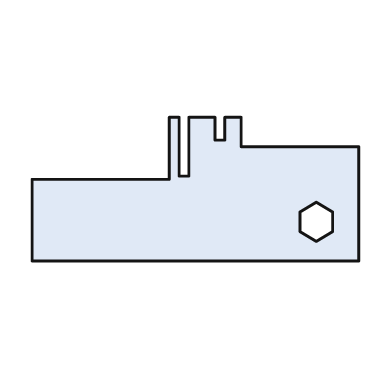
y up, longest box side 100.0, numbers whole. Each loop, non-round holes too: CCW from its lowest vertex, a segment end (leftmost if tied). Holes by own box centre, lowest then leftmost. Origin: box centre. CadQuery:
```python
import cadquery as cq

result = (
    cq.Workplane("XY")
    .moveTo(-50.0, -22.0)
    .lineTo(50.0, -22.0)
    .lineTo(50.0, 13.0)
    .lineTo(14.0, 13.0)
    .lineTo(14.0, 22.0)
    .lineTo(9.0, 22.0)
    .lineTo(9.0, 15.0)
    .lineTo(6.0, 15.0)
    .lineTo(6.0, 22.0)
    .lineTo(-2.0, 22.0)
    .lineTo(-2.0, 4.0)
    .lineTo(-5.0, 4.0)
    .lineTo(-5.0, 22.0)
    .lineTo(-8.0, 22.0)
    .lineTo(-8.0, 3.0)
    .lineTo(-50.0, 3.0)
    .close()
    .moveTo(37.0, -16.0)
    .lineTo(42.0, -13.0)
    .lineTo(42.0, -7.0)
    .lineTo(37.0, -4.0)
    .lineTo(32.0, -7.0)
    .lineTo(32.0, -13.0)
    .close()
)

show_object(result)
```